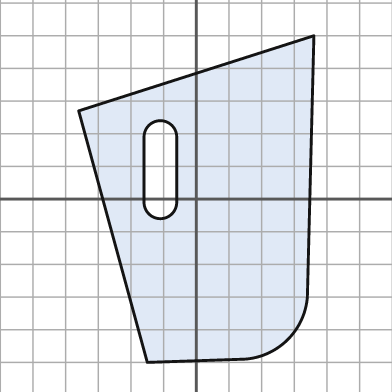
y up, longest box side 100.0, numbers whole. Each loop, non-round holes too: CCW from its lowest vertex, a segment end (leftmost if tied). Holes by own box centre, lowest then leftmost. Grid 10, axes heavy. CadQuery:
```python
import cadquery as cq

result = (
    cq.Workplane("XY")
    .moveTo(-15.0, -50.0)
    .lineTo(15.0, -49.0)
    .threePointArc((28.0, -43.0), (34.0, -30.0))
    .lineTo(36.0, 50.0)
    .lineTo(-36.0, 27.0)
    .close()
    .moveTo(-16.0, -1.0)
    .threePointArc((-11.0, -6.0), (-6.0, -1.0))
    .lineTo(-6.0, 19.0)
    .threePointArc((-11.0, 24.0), (-16.0, 19.0))
    .close()
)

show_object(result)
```